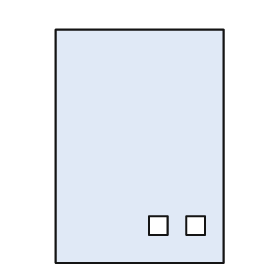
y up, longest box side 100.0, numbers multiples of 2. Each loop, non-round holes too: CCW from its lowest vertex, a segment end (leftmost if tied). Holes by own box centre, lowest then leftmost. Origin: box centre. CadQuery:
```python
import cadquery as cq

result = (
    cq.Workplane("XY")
    .moveTo(-36.0, -50.0)
    .lineTo(36.0, -50.0)
    .lineTo(36.0, 50.0)
    .lineTo(-36.0, 50.0)
    .close()
    .moveTo(4.0, -38.0)
    .lineTo(12.0, -38.0)
    .lineTo(12.0, -30.0)
    .lineTo(4.0, -30.0)
    .close()
    .moveTo(20.0, -38.0)
    .lineTo(28.0, -38.0)
    .lineTo(28.0, -30.0)
    .lineTo(20.0, -30.0)
    .close()
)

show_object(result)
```